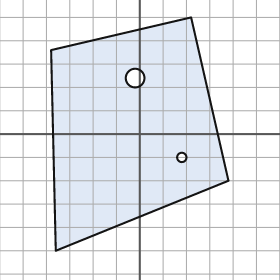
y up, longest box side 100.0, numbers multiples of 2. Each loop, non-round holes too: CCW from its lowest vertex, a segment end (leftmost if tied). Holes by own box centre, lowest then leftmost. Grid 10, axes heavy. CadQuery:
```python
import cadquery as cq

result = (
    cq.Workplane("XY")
    .moveTo(-36.0, -50.0)
    .lineTo(38.0, -20.0)
    .lineTo(22.0, 50.0)
    .lineTo(-38.0, 36.0)
    .close()
    .moveTo(18.0, -10.0)
    .circle(2.0)
    .moveTo(-2.0, 24.0)
    .circle(4.0)
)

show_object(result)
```